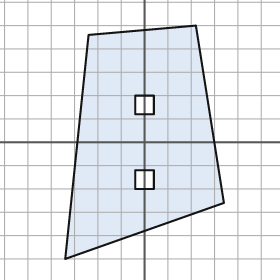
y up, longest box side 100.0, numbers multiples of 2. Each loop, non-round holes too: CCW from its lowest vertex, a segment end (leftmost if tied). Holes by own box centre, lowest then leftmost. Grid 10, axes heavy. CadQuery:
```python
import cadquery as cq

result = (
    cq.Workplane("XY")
    .moveTo(-34.0, -50.0)
    .lineTo(34.0, -26.0)
    .lineTo(22.0, 50.0)
    .lineTo(-24.0, 46.0)
    .close()
    .moveTo(-4.0, -20.0)
    .lineTo(4.0, -20.0)
    .lineTo(4.0, -12.0)
    .lineTo(-4.0, -12.0)
    .close()
    .moveTo(-4.0, 12.0)
    .lineTo(4.0, 12.0)
    .lineTo(4.0, 20.0)
    .lineTo(-4.0, 20.0)
    .close()
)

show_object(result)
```